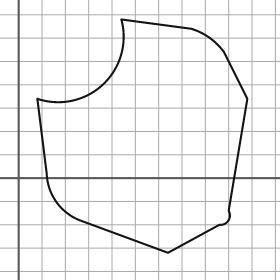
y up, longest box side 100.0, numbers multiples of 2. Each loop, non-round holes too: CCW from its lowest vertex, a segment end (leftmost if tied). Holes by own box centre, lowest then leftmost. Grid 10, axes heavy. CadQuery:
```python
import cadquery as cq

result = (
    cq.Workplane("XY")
    .moveTo(64.0, -32.0)
    .lineTo(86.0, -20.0)
    .threePointArc((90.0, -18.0), (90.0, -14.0))
    .lineTo(98.0, 34.0)
    .lineTo(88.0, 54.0)
    .threePointArc((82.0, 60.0), (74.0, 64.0))
    .lineTo(44.0, 68.0)
    .threePointArc((36.0, 40.0), (8.0, 34.0))
    .lineTo(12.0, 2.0)
    .threePointArc((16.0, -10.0), (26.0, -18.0))
    .close()
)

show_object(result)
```